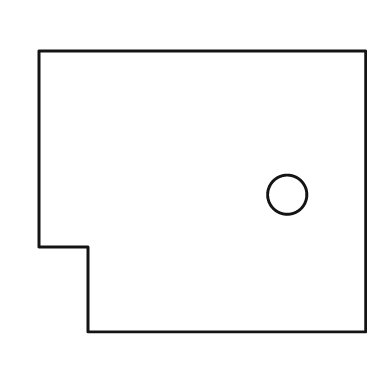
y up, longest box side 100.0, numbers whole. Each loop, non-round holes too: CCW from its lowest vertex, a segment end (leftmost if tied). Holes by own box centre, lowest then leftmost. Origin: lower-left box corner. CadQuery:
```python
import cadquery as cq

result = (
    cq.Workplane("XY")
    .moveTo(15.0, 0.0)
    .lineTo(100.0, 0.0)
    .lineTo(100.0, 86.0)
    .lineTo(0.0, 86.0)
    .lineTo(0.0, 26.0)
    .lineTo(15.0, 26.0)
    .close()
    .moveTo(76.0, 42.0)
    .circle(6.0)
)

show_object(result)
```